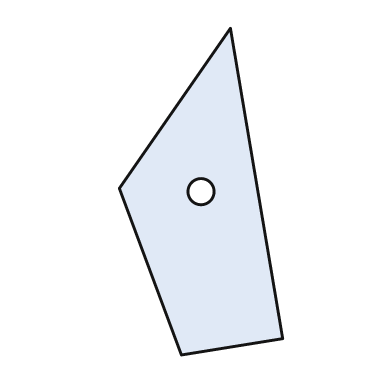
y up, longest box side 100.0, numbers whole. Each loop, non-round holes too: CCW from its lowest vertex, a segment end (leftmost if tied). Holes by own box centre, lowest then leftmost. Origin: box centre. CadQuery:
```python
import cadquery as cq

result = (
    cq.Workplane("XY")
    .moveTo(-6.0, -50.0)
    .lineTo(25.0, -45.0)
    .lineTo(9.0, 50.0)
    .lineTo(-25.0, 1.0)
    .close()
    .moveTo(0.0, 0.0)
    .circle(4.0)
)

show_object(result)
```